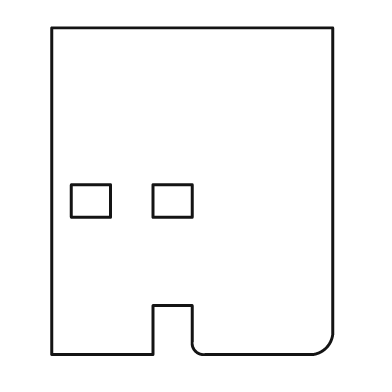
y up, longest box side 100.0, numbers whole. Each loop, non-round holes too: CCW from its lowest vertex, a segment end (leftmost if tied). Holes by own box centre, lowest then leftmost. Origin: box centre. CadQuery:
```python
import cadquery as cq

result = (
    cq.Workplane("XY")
    .moveTo(-43.0, -50.0)
    .lineTo(-12.0, -50.0)
    .lineTo(-12.0, -35.0)
    .lineTo(0.0, -35.0)
    .lineTo(0.0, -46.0)
    .threePointArc((1.0, -49.0), (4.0, -50.0))
    .lineTo(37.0, -50.0)
    .threePointArc((41.0, -48.0), (43.0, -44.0))
    .lineTo(43.0, 50.0)
    .lineTo(-43.0, 50.0)
    .close()
    .moveTo(-37.0, -8.0)
    .lineTo(-25.0, -8.0)
    .lineTo(-25.0, 2.0)
    .lineTo(-37.0, 2.0)
    .close()
    .moveTo(-12.0, -8.0)
    .lineTo(0.0, -8.0)
    .lineTo(0.0, 2.0)
    .lineTo(-12.0, 2.0)
    .close()
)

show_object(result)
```